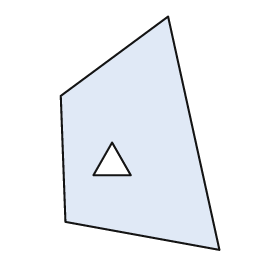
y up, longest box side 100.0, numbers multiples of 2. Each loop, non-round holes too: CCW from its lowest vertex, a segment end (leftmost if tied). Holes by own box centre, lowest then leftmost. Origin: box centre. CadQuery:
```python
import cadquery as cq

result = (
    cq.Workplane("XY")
    .moveTo(34.0, -50.0)
    .lineTo(12.0, 50.0)
    .lineTo(-34.0, 16.0)
    .lineTo(-32.0, -38.0)
    .close()
    .moveTo(-20.0, -18.0)
    .lineTo(-4.0, -18.0)
    .lineTo(-12.0, -4.0)
    .close()
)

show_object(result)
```